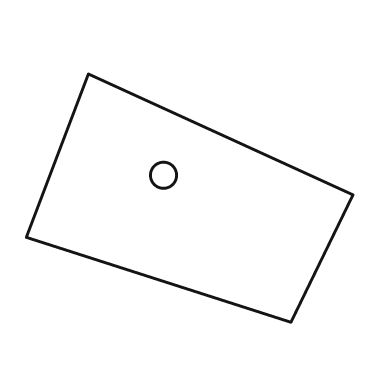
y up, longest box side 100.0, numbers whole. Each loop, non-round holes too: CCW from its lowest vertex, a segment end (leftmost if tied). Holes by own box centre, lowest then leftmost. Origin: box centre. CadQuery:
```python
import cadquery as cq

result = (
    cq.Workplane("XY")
    .moveTo(31.0, -38.0)
    .lineTo(50.0, 1.0)
    .lineTo(-31.0, 38.0)
    .lineTo(-50.0, -12.0)
    .close()
    .moveTo(-8.0, 7.0)
    .circle(4.0)
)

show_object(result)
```